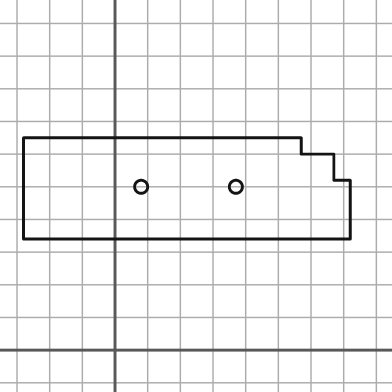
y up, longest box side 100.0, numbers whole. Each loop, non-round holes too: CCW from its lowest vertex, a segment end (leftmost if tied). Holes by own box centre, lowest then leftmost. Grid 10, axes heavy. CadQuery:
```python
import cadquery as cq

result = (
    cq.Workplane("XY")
    .moveTo(-28.0, 34.0)
    .lineTo(72.0, 34.0)
    .lineTo(72.0, 52.0)
    .lineTo(67.0, 52.0)
    .lineTo(67.0, 60.0)
    .lineTo(57.0, 60.0)
    .lineTo(57.0, 65.0)
    .lineTo(-28.0, 65.0)
    .close()
    .moveTo(8.0, 50.0)
    .circle(2.0)
    .moveTo(37.0, 50.0)
    .circle(2.0)
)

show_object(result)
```